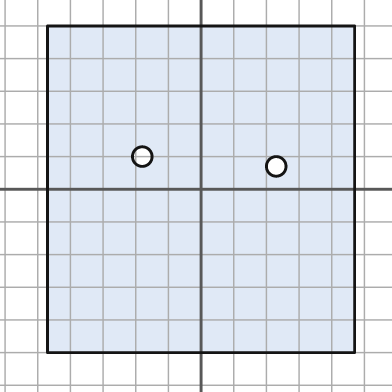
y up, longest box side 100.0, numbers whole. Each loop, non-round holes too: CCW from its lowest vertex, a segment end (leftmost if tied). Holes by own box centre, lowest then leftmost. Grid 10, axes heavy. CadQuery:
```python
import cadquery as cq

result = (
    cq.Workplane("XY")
    .moveTo(-47.0, -50.0)
    .lineTo(47.0, -50.0)
    .lineTo(47.0, 50.0)
    .lineTo(-47.0, 50.0)
    .close()
    .moveTo(23.0, 7.0)
    .circle(3.0)
    .moveTo(-18.0, 10.0)
    .circle(3.0)
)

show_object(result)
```